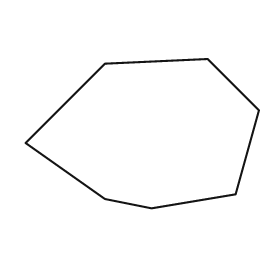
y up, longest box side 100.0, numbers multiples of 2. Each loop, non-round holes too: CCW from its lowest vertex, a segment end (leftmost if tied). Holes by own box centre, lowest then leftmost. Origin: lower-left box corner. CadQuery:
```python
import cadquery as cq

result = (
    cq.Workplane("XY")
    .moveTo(54.0, 0.0)
    .lineTo(90.0, 6.0)
    .lineTo(100.0, 42.0)
    .lineTo(78.0, 64.0)
    .lineTo(34.0, 62.0)
    .lineTo(0.0, 28.0)
    .lineTo(34.0, 4.0)
    .close()
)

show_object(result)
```